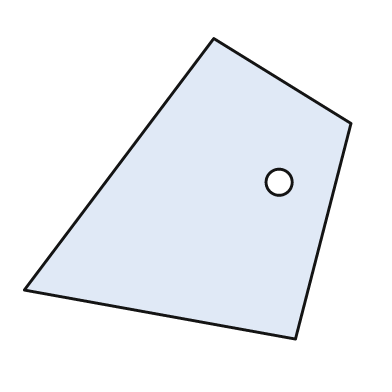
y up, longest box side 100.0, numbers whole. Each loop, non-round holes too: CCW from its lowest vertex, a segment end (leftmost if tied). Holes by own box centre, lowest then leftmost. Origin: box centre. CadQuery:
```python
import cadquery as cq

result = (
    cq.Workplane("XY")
    .moveTo(33.0, -46.0)
    .lineTo(50.0, 20.0)
    .lineTo(8.0, 46.0)
    .lineTo(-50.0, -31.0)
    .close()
    .moveTo(28.0, 2.0)
    .circle(4.0)
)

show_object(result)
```